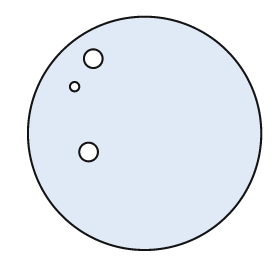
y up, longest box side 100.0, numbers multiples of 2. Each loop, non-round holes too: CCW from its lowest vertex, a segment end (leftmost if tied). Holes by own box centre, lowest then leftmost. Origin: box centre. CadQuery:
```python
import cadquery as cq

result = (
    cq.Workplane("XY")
    .moveTo(0.0, 0.0)
    .circle(50.0)
    .moveTo(-24.0, -8.0)
    .circle(4.0)
    .moveTo(-30.0, 20.0)
    .circle(2.0)
    .moveTo(-22.0, 32.0)
    .circle(4.0)
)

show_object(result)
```